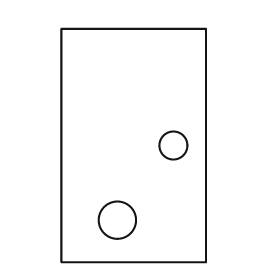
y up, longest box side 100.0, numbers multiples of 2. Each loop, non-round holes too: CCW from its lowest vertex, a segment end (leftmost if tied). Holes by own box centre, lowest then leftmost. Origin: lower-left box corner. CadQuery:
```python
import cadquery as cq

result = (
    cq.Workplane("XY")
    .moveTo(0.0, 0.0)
    .lineTo(62.0, 0.0)
    .lineTo(62.0, 100.0)
    .lineTo(0.0, 100.0)
    .close()
    .moveTo(24.0, 18.0)
    .circle(8.0)
    .moveTo(48.0, 50.0)
    .circle(6.0)
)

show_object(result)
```